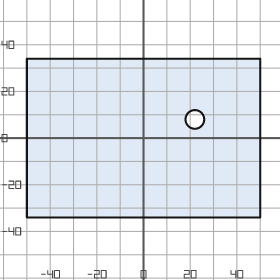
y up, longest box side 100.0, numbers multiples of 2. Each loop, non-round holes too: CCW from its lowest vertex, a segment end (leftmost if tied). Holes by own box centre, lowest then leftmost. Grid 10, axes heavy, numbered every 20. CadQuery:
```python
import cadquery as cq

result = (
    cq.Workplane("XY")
    .moveTo(-50.0, -34.0)
    .lineTo(50.0, -34.0)
    .lineTo(50.0, 34.0)
    .lineTo(-50.0, 34.0)
    .close()
    .moveTo(22.0, 8.0)
    .circle(4.0)
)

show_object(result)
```